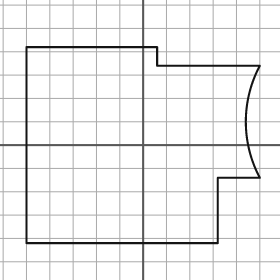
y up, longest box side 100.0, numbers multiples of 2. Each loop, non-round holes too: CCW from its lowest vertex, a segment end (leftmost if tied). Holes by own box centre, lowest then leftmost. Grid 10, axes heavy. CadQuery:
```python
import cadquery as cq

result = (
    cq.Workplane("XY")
    .moveTo(-50.0, -42.0)
    .lineTo(32.0, -42.0)
    .lineTo(32.0, -14.0)
    .lineTo(50.0, -14.0)
    .threePointArc((44.0, 10.0), (50.0, 34.0))
    .lineTo(6.0, 34.0)
    .lineTo(6.0, 42.0)
    .lineTo(-50.0, 42.0)
    .close()
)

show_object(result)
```